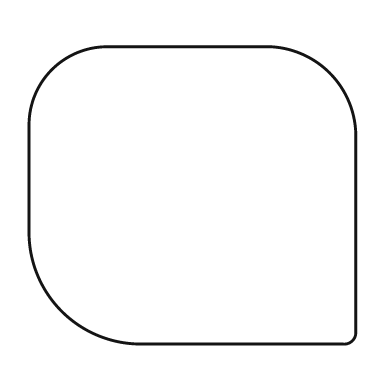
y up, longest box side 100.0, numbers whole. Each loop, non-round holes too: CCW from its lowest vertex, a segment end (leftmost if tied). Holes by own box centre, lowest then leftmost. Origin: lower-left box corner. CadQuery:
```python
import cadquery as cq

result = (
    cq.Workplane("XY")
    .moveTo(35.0, 0.0)
    .lineTo(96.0, 0.0)
    .threePointArc((99.0, 1.0), (100.0, 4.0))
    .lineTo(100.0, 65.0)
    .threePointArc((92.0, 83.0), (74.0, 91.0))
    .lineTo(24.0, 91.0)
    .threePointArc((7.0, 84.0), (0.0, 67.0))
    .lineTo(0.0, 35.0)
    .threePointArc((10.0, 10.0), (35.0, 0.0))
    .close()
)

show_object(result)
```